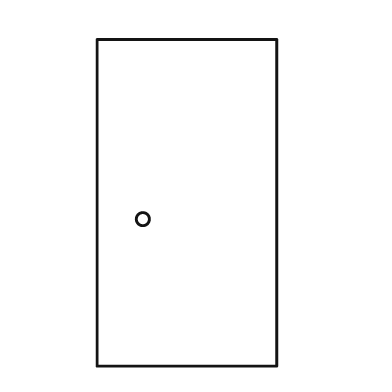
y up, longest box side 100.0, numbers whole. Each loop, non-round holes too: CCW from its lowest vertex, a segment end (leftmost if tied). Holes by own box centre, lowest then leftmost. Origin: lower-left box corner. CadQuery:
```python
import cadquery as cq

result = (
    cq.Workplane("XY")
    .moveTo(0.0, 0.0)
    .lineTo(55.0, 0.0)
    .lineTo(55.0, 100.0)
    .lineTo(0.0, 100.0)
    .close()
    .moveTo(14.0, 45.0)
    .circle(2.0)
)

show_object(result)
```